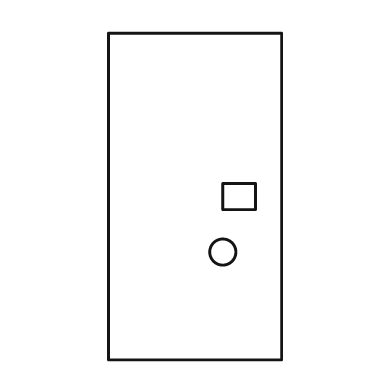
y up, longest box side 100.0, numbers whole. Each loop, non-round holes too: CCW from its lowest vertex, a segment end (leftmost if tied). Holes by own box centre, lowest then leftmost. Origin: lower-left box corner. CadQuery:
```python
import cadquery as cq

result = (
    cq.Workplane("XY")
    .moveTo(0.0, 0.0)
    .lineTo(53.0, 0.0)
    .lineTo(53.0, 100.0)
    .lineTo(0.0, 100.0)
    .close()
    .moveTo(35.0, 33.0)
    .circle(4.0)
    .moveTo(35.0, 46.0)
    .lineTo(45.0, 46.0)
    .lineTo(45.0, 54.0)
    .lineTo(35.0, 54.0)
    .close()
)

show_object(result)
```